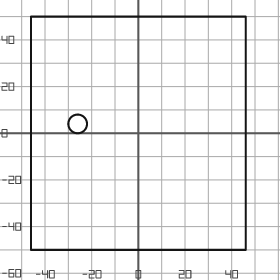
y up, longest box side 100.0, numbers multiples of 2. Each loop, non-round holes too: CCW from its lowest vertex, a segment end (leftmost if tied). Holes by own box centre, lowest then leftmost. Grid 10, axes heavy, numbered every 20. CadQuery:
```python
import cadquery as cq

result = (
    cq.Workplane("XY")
    .moveTo(-46.0, -50.0)
    .lineTo(46.0, -50.0)
    .lineTo(46.0, 50.0)
    .lineTo(-46.0, 50.0)
    .close()
    .moveTo(-26.0, 4.0)
    .circle(4.0)
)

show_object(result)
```